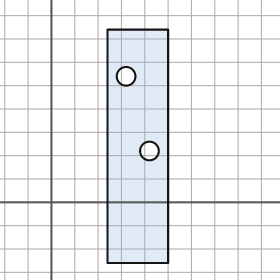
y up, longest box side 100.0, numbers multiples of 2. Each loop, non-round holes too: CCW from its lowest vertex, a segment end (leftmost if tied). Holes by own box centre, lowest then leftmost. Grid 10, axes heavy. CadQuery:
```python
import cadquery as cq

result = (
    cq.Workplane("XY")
    .moveTo(24.0, -26.0)
    .lineTo(50.0, -26.0)
    .lineTo(50.0, 74.0)
    .lineTo(24.0, 74.0)
    .close()
    .moveTo(42.0, 22.0)
    .circle(4.0)
    .moveTo(32.0, 54.0)
    .circle(4.0)
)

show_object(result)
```